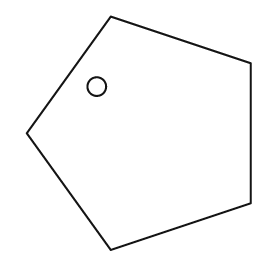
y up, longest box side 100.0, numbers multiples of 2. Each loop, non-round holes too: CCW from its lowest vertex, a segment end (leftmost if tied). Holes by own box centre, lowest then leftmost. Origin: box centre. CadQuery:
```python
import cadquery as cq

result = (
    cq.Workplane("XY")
    .moveTo(-12.0, -50.0)
    .lineTo(48.0, -30.0)
    .lineTo(48.0, 30.0)
    .lineTo(-12.0, 50.0)
    .lineTo(-48.0, 0.0)
    .close()
    .moveTo(-18.0, 20.0)
    .circle(4.0)
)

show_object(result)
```